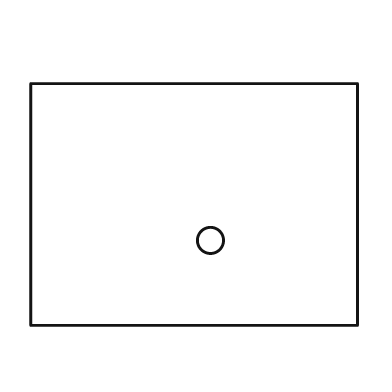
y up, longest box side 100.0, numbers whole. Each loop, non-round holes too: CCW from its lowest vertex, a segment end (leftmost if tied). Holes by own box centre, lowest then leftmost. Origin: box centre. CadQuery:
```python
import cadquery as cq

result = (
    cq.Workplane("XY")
    .moveTo(-50.0, -37.0)
    .lineTo(50.0, -37.0)
    .lineTo(50.0, 37.0)
    .lineTo(-50.0, 37.0)
    .close()
    .moveTo(5.0, -11.0)
    .circle(4.0)
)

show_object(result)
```